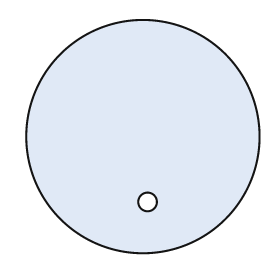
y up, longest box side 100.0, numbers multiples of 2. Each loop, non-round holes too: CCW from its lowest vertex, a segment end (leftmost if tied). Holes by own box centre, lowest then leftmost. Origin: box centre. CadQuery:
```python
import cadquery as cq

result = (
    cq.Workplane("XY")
    .moveTo(0.0, 0.0)
    .circle(50.0)
    .moveTo(2.0, -28.0)
    .circle(4.0)
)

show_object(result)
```